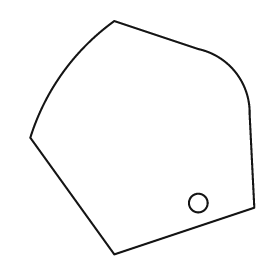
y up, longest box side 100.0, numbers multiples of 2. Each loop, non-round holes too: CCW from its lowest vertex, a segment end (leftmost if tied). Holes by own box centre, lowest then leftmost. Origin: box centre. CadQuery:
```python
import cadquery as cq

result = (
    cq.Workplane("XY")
    .moveTo(-12.0, -50.0)
    .lineTo(48.0, -30.0)
    .lineTo(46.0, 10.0)
    .threePointArc((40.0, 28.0), (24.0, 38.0))
    .lineTo(-12.0, 50.0)
    .threePointArc((-34.0, 28.0), (-48.0, 0.0))
    .close()
    .moveTo(24.0, -28.0)
    .circle(4.0)
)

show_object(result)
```